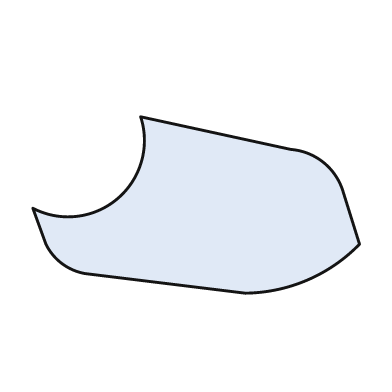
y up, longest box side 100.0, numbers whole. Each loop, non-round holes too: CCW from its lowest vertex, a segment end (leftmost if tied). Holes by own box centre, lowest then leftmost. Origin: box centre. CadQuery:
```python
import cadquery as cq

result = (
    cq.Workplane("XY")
    .moveTo(15.0, -27.0)
    .threePointArc((34.0, -23.0), (50.0, -12.0))
    .lineTo(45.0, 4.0)
    .threePointArc((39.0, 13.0), (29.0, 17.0))
    .lineTo(-17.0, 27.0)
    .threePointArc((-24.0, 2.0), (-50.0, -1.0))
    .lineTo(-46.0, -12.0)
    .threePointArc((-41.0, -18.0), (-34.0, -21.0))
    .close()
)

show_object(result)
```